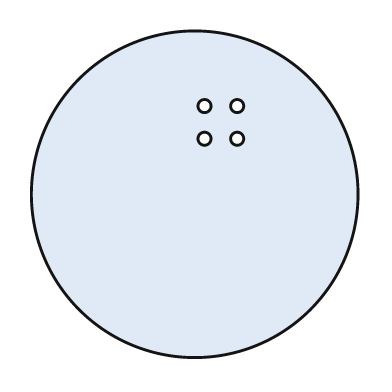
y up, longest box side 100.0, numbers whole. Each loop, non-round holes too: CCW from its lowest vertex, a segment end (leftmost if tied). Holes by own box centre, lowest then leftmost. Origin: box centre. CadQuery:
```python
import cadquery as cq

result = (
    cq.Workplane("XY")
    .moveTo(0.0, 0.0)
    .circle(50.0)
    .moveTo(3.0, 17.0)
    .circle(2.0)
    .moveTo(13.0, 17.0)
    .circle(2.0)
    .moveTo(3.0, 27.0)
    .circle(2.0)
    .moveTo(13.0, 27.0)
    .circle(2.0)
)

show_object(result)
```